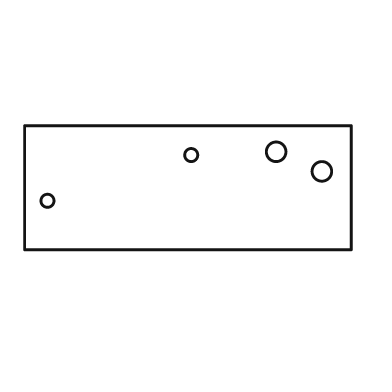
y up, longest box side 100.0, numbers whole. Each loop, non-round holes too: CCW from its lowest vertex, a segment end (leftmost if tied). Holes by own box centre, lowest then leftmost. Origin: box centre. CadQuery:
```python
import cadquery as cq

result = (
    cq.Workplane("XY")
    .moveTo(-50.0, -19.0)
    .lineTo(50.0, -19.0)
    .lineTo(50.0, 19.0)
    .lineTo(-50.0, 19.0)
    .close()
    .moveTo(-43.0, -4.0)
    .circle(2.0)
    .moveTo(41.0, 5.0)
    .circle(3.0)
    .moveTo(1.0, 10.0)
    .circle(2.0)
    .moveTo(27.0, 11.0)
    .circle(3.0)
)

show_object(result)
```